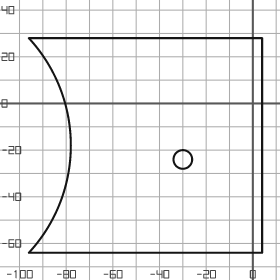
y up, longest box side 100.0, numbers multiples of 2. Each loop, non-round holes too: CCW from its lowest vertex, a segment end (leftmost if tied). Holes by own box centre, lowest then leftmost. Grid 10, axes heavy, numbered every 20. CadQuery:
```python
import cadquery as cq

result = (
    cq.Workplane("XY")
    .moveTo(-96.0, -64.0)
    .lineTo(4.0, -64.0)
    .lineTo(4.0, 28.0)
    .lineTo(-96.0, 28.0)
    .threePointArc((-78.0, -18.0), (-96.0, -64.0))
    .close()
    .moveTo(-30.0, -24.0)
    .circle(4.0)
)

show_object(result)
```